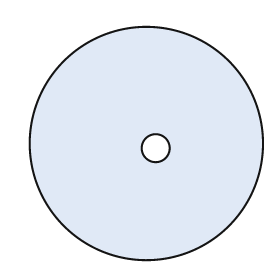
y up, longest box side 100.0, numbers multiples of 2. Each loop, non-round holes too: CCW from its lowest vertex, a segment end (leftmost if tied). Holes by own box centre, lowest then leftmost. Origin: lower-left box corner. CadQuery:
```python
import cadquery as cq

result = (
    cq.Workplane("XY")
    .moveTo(50.0, 50.0)
    .circle(50.0)
    .moveTo(54.0, 48.0)
    .circle(6.0)
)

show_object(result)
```